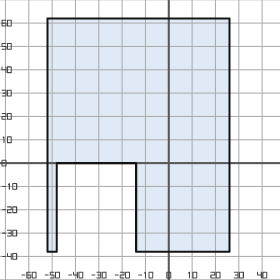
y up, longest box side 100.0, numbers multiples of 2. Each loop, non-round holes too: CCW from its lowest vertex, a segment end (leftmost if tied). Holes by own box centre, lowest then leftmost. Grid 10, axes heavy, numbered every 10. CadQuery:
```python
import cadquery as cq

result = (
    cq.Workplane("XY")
    .moveTo(-52.0, -38.0)
    .lineTo(-48.0, -38.0)
    .lineTo(-48.0, 0.0)
    .lineTo(-14.0, 0.0)
    .lineTo(-14.0, -38.0)
    .lineTo(26.0, -38.0)
    .lineTo(26.0, 62.0)
    .lineTo(-52.0, 62.0)
    .close()
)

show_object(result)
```